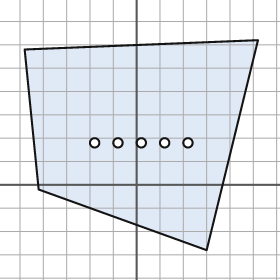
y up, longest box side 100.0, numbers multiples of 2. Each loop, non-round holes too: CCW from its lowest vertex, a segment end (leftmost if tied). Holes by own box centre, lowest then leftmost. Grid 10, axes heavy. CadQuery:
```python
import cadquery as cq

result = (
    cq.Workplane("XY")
    .moveTo(30.0, -28.0)
    .lineTo(52.0, 62.0)
    .lineTo(-48.0, 58.0)
    .lineTo(-42.0, -2.0)
    .close()
    .moveTo(-18.0, 18.0)
    .circle(2.0)
    .moveTo(-8.0, 18.0)
    .circle(2.0)
    .moveTo(2.0, 18.0)
    .circle(2.0)
    .moveTo(12.0, 18.0)
    .circle(2.0)
    .moveTo(22.0, 18.0)
    .circle(2.0)
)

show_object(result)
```